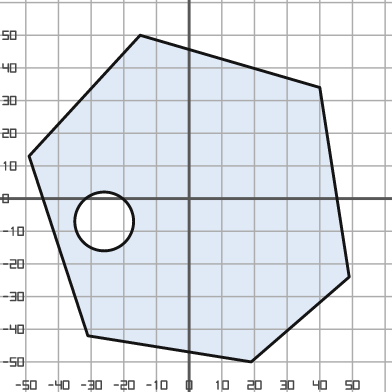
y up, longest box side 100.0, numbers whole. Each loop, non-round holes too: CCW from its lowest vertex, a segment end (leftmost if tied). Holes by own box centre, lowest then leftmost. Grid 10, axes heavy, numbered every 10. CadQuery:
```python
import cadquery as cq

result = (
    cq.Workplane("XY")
    .moveTo(19.0, -50.0)
    .lineTo(49.0, -24.0)
    .lineTo(40.0, 34.0)
    .lineTo(-15.0, 50.0)
    .lineTo(-49.0, 13.0)
    .lineTo(-31.0, -42.0)
    .close()
    .moveTo(-26.0, -7.0)
    .circle(9.0)
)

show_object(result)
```